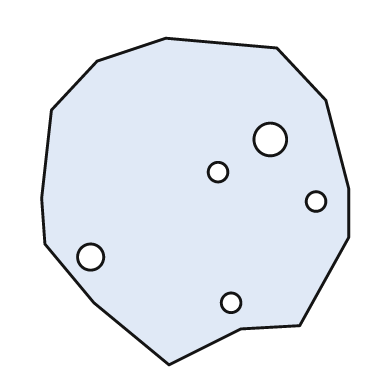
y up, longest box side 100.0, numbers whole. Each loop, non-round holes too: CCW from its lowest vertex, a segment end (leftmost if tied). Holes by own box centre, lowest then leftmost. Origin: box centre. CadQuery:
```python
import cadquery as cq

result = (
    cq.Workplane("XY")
    .moveTo(-8.0, -50.0)
    .lineTo(14.0, -39.0)
    .lineTo(32.0, -38.0)
    .lineTo(47.0, -11.0)
    .lineTo(47.0, 4.0)
    .lineTo(40.0, 31.0)
    .lineTo(25.0, 47.0)
    .lineTo(-9.0, 50.0)
    .lineTo(-30.0, 43.0)
    .lineTo(-44.0, 28.0)
    .lineTo(-47.0, 1.0)
    .lineTo(-46.0, -13.0)
    .lineTo(-31.0, -31.0)
    .close()
    .moveTo(11.0, -31.0)
    .circle(3.0)
    .moveTo(-32.0, -17.0)
    .circle(4.0)
    .moveTo(37.0, 0.0)
    .circle(3.0)
    .moveTo(7.0, 9.0)
    .circle(3.0)
    .moveTo(23.0, 19.0)
    .circle(5.0)
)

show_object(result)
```